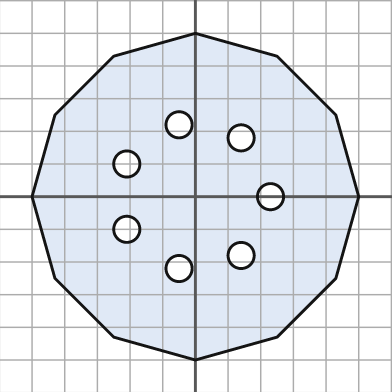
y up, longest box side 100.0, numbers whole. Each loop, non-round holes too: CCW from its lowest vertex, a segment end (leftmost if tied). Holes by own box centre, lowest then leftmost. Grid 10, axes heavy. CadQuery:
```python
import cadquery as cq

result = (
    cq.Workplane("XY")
    .moveTo(0.0, -50.0)
    .lineTo(25.0, -43.0)
    .lineTo(43.0, -25.0)
    .lineTo(50.0, 0.0)
    .lineTo(43.0, 25.0)
    .lineTo(25.0, 43.0)
    .lineTo(0.0, 50.0)
    .lineTo(-25.0, 43.0)
    .lineTo(-43.0, 25.0)
    .lineTo(-50.0, 0.0)
    .lineTo(-43.0, -25.0)
    .lineTo(-25.0, -43.0)
    .close()
    .moveTo(-5.0, -22.0)
    .circle(4.0)
    .moveTo(14.0, -18.0)
    .circle(4.0)
    .moveTo(-21.0, -10.0)
    .circle(4.0)
    .moveTo(23.0, 0.0)
    .circle(4.0)
    .moveTo(-21.0, 10.0)
    .circle(4.0)
    .moveTo(14.0, 18.0)
    .circle(4.0)
    .moveTo(-5.0, 22.0)
    .circle(4.0)
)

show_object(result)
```